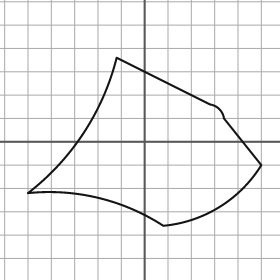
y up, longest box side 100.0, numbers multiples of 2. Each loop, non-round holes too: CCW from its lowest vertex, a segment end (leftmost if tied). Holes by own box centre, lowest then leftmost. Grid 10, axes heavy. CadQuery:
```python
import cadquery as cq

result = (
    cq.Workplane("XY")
    .moveTo(8.0, -36.0)
    .threePointArc((32.0, -28.0), (50.0, -10.0))
    .lineTo(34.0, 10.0)
    .threePointArc((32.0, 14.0), (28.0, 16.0))
    .lineTo(-12.0, 36.0)
    .threePointArc((-26.0, 4.0), (-50.0, -22.0))
    .threePointArc((-20.0, -24.0), (8.0, -36.0))
    .close()
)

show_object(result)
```